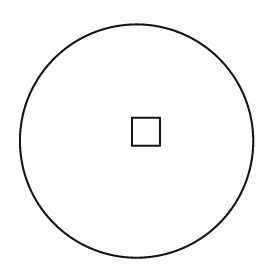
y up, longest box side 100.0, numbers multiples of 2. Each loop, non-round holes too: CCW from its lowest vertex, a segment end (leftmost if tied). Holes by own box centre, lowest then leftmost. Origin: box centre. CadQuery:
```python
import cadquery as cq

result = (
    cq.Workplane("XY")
    .moveTo(0.0, 0.0)
    .circle(50.0)
    .moveTo(-2.0, -2.0)
    .lineTo(10.0, -2.0)
    .lineTo(10.0, 10.0)
    .lineTo(-2.0, 10.0)
    .close()
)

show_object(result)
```